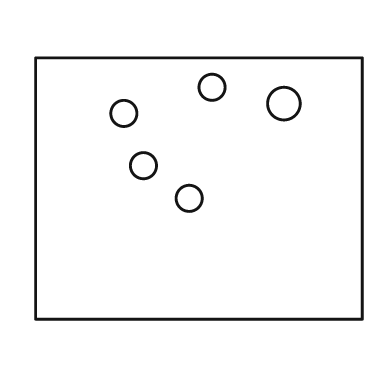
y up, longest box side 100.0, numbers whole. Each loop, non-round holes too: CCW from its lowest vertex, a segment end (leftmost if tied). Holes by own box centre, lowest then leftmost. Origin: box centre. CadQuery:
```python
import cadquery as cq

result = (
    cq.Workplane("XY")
    .moveTo(-50.0, -40.0)
    .lineTo(50.0, -40.0)
    .lineTo(50.0, 40.0)
    .lineTo(-50.0, 40.0)
    .close()
    .moveTo(-3.0, -3.0)
    .circle(4.0)
    .moveTo(-17.0, 7.0)
    .circle(4.0)
    .moveTo(-23.0, 23.0)
    .circle(4.0)
    .moveTo(26.0, 26.0)
    .circle(5.0)
    .moveTo(4.0, 31.0)
    .circle(4.0)
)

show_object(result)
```